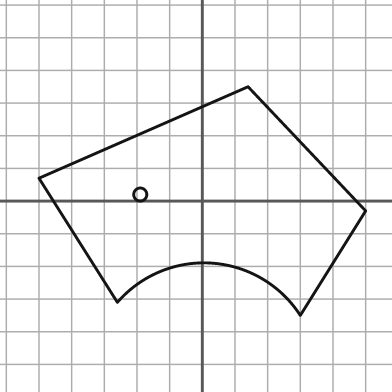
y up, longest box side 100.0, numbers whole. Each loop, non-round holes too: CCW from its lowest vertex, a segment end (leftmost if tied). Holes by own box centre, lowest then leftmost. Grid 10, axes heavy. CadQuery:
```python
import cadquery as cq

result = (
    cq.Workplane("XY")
    .moveTo(30.0, -35.0)
    .lineTo(50.0, -3.0)
    .lineTo(14.0, 35.0)
    .lineTo(-50.0, 7.0)
    .lineTo(-26.0, -31.0)
    .threePointArc((3.0, -19.0), (30.0, -35.0))
    .close()
    .moveTo(-19.0, 2.0)
    .circle(2.0)
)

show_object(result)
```